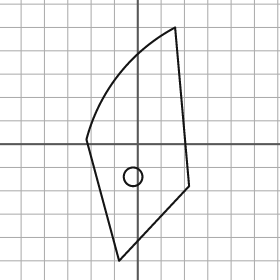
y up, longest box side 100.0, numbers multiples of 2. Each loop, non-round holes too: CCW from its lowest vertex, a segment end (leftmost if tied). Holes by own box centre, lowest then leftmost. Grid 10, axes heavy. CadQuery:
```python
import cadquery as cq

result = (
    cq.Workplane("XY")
    .moveTo(-8.0, -50.0)
    .lineTo(22.0, -18.0)
    .lineTo(16.0, 50.0)
    .threePointArc((-8.0, 30.0), (-22.0, 2.0))
    .close()
    .moveTo(-2.0, -14.0)
    .circle(4.0)
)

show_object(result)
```